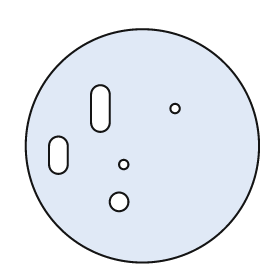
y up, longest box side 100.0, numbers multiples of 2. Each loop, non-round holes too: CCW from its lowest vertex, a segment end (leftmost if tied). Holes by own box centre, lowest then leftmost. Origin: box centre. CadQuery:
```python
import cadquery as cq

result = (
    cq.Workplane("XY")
    .moveTo(0.0, 0.0)
    .circle(50.0)
    .moveTo(-10.0, -24.0)
    .circle(4.0)
    .moveTo(-8.0, -8.0)
    .circle(2.0)
    .moveTo(-40.0, -8.0)
    .threePointArc((-36.0, -12.0), (-32.0, -8.0))
    .lineTo(-32.0, 0.0)
    .threePointArc((-36.0, 4.0), (-40.0, 0.0))
    .close()
    .moveTo(-22.0, 10.0)
    .threePointArc((-18.0, 6.0), (-14.0, 10.0))
    .lineTo(-14.0, 22.0)
    .threePointArc((-18.0, 26.0), (-22.0, 22.0))
    .close()
    .moveTo(14.0, 16.0)
    .circle(2.0)
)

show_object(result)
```